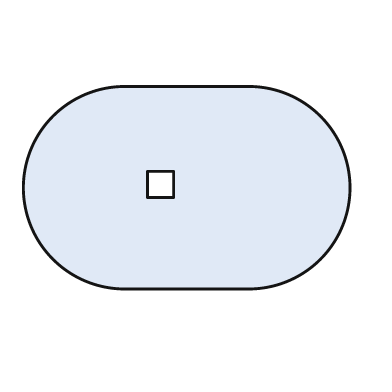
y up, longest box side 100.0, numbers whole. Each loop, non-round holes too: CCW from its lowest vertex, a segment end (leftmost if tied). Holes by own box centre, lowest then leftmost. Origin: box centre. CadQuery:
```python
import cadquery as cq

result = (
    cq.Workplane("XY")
    .moveTo(-19.0, -31.0)
    .lineTo(19.0, -31.0)
    .threePointArc((50.0, 0.0), (19.0, 31.0))
    .lineTo(-19.0, 31.0)
    .threePointArc((-50.0, 0.0), (-19.0, -31.0))
    .close()
    .moveTo(-12.0, -3.0)
    .lineTo(-4.0, -3.0)
    .lineTo(-4.0, 5.0)
    .lineTo(-12.0, 5.0)
    .close()
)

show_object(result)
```